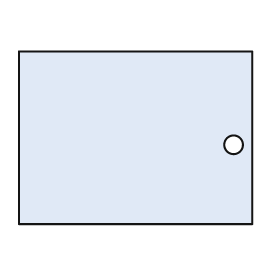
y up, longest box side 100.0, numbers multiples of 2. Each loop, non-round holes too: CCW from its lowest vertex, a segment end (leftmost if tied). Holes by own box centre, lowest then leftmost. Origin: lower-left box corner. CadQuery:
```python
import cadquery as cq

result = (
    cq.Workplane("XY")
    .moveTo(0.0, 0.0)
    .lineTo(100.0, 0.0)
    .lineTo(100.0, 74.0)
    .lineTo(0.0, 74.0)
    .close()
    .moveTo(92.0, 34.0)
    .circle(4.0)
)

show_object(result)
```